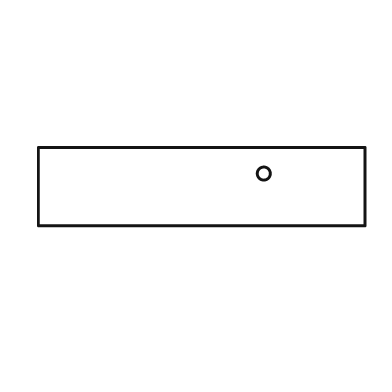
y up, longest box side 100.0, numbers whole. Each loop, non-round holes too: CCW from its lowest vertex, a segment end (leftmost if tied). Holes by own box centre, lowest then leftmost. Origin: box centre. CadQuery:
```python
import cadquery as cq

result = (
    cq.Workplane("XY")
    .moveTo(-50.0, -12.0)
    .lineTo(50.0, -12.0)
    .lineTo(50.0, 12.0)
    .lineTo(-50.0, 12.0)
    .close()
    .moveTo(19.0, 4.0)
    .circle(2.0)
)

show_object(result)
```